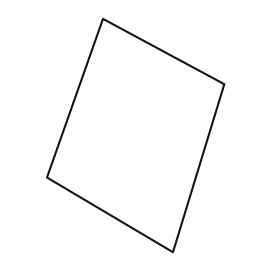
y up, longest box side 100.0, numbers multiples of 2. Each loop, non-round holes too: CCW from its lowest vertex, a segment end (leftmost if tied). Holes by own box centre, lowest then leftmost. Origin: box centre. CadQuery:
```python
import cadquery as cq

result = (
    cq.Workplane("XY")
    .moveTo(16.0, -50.0)
    .lineTo(38.0, 22.0)
    .lineTo(-14.0, 50.0)
    .lineTo(-38.0, -18.0)
    .close()
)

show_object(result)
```